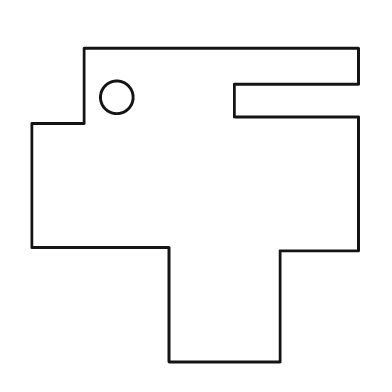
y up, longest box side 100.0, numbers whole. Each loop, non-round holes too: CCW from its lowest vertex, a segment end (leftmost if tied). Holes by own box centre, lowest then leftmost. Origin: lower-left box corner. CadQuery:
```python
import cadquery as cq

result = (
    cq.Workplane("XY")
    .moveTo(42.0, 0.0)
    .lineTo(76.0, 0.0)
    .lineTo(76.0, 34.0)
    .lineTo(100.0, 34.0)
    .lineTo(100.0, 75.0)
    .lineTo(62.0, 75.0)
    .lineTo(62.0, 85.0)
    .lineTo(100.0, 85.0)
    .lineTo(100.0, 96.0)
    .lineTo(16.0, 96.0)
    .lineTo(16.0, 73.0)
    .lineTo(0.0, 73.0)
    .lineTo(0.0, 35.0)
    .lineTo(42.0, 35.0)
    .close()
    .moveTo(26.0, 81.0)
    .circle(5.0)
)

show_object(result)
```